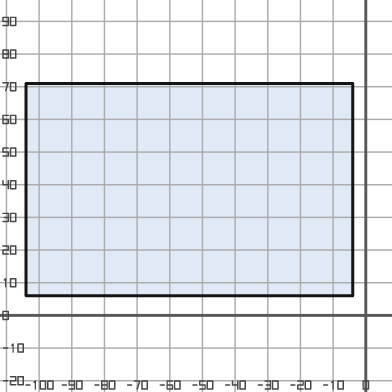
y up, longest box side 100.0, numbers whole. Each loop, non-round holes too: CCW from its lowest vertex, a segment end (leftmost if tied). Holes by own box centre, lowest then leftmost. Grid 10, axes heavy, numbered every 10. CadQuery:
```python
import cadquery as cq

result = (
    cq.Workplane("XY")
    .moveTo(-104.0, 6.0)
    .lineTo(-4.0, 6.0)
    .lineTo(-4.0, 71.0)
    .lineTo(-104.0, 71.0)
    .close()
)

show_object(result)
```